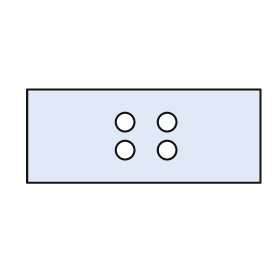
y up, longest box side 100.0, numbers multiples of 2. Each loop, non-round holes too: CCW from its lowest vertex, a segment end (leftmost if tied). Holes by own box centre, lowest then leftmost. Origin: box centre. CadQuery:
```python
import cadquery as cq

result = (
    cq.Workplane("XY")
    .moveTo(-50.0, -20.0)
    .lineTo(50.0, -20.0)
    .lineTo(50.0, 20.0)
    .lineTo(-50.0, 20.0)
    .close()
    .moveTo(-8.0, -6.0)
    .circle(4.0)
    .moveTo(10.0, -6.0)
    .circle(4.0)
    .moveTo(-8.0, 6.0)
    .circle(4.0)
    .moveTo(10.0, 6.0)
    .circle(4.0)
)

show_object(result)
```